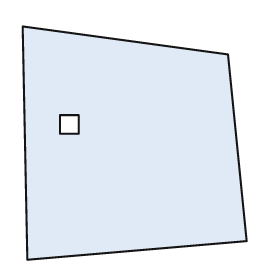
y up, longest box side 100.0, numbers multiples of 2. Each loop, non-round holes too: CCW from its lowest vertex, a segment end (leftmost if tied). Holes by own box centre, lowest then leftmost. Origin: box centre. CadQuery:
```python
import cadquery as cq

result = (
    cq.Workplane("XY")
    .moveTo(-46.0, -50.0)
    .lineTo(48.0, -42.0)
    .lineTo(40.0, 38.0)
    .lineTo(-48.0, 50.0)
    .close()
    .moveTo(-32.0, 4.0)
    .lineTo(-24.0, 4.0)
    .lineTo(-24.0, 12.0)
    .lineTo(-32.0, 12.0)
    .close()
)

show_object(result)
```